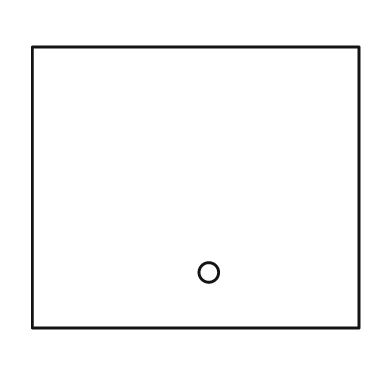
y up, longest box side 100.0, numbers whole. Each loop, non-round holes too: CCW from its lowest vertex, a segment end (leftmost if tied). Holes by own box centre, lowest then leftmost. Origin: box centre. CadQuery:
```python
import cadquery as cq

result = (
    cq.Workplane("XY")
    .moveTo(-50.0, -43.0)
    .lineTo(50.0, -43.0)
    .lineTo(50.0, 43.0)
    .lineTo(-50.0, 43.0)
    .close()
    .moveTo(4.0, -26.0)
    .circle(3.0)
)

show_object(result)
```